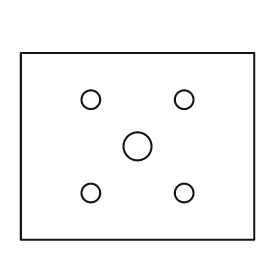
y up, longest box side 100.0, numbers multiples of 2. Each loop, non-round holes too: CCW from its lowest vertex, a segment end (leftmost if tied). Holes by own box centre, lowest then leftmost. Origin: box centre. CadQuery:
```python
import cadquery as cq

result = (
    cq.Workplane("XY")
    .moveTo(-50.0, -40.0)
    .lineTo(50.0, -40.0)
    .lineTo(50.0, 40.0)
    .lineTo(-50.0, 40.0)
    .close()
    .moveTo(-20.0, -20.0)
    .circle(4.0)
    .moveTo(20.0, -20.0)
    .circle(4.0)
    .moveTo(0.0, 0.0)
    .circle(6.0)
    .moveTo(-20.0, 20.0)
    .circle(4.0)
    .moveTo(20.0, 20.0)
    .circle(4.0)
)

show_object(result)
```